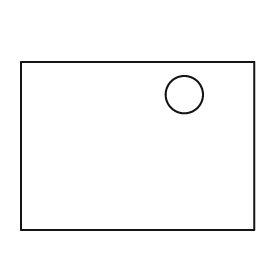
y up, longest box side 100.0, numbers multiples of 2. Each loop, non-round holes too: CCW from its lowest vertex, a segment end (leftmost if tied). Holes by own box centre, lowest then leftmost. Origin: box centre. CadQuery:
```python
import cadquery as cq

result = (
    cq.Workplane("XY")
    .moveTo(-50.0, -36.0)
    .lineTo(50.0, -36.0)
    .lineTo(50.0, 36.0)
    .lineTo(-50.0, 36.0)
    .close()
    .moveTo(20.0, 22.0)
    .circle(8.0)
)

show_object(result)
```